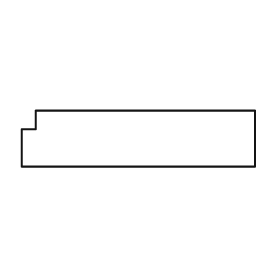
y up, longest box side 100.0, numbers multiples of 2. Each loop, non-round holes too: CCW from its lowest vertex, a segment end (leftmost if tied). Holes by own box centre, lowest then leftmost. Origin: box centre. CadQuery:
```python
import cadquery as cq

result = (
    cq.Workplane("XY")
    .moveTo(-50.0, -12.0)
    .lineTo(50.0, -12.0)
    .lineTo(50.0, 12.0)
    .lineTo(-44.0, 12.0)
    .lineTo(-44.0, 4.0)
    .lineTo(-50.0, 4.0)
    .close()
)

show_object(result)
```